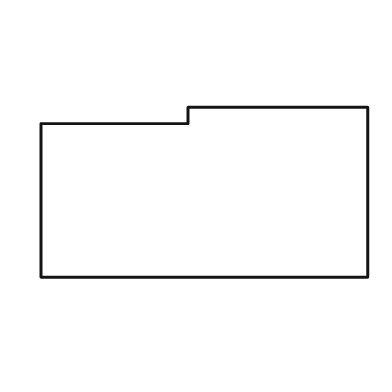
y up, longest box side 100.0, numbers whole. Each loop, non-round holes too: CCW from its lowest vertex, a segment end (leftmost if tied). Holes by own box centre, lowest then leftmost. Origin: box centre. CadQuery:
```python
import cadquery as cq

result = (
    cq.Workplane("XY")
    .moveTo(-50.0, -26.0)
    .lineTo(50.0, -26.0)
    .lineTo(50.0, 26.0)
    .lineTo(-5.0, 26.0)
    .lineTo(-5.0, 21.0)
    .lineTo(-50.0, 21.0)
    .close()
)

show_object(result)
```